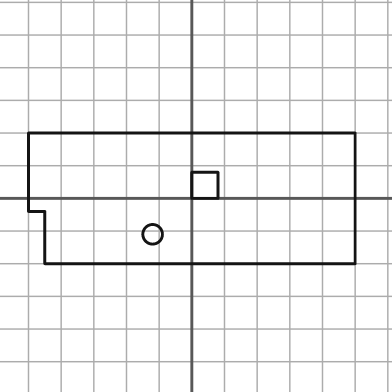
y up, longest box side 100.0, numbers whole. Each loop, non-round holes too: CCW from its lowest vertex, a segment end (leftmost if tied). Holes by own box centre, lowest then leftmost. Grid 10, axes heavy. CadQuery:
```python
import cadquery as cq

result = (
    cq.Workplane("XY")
    .moveTo(-45.0, -20.0)
    .lineTo(50.0, -20.0)
    .lineTo(50.0, 20.0)
    .lineTo(-50.0, 20.0)
    .lineTo(-50.0, -4.0)
    .lineTo(-45.0, -4.0)
    .close()
    .moveTo(-12.0, -11.0)
    .circle(3.0)
    .moveTo(0.0, 0.0)
    .lineTo(8.0, 0.0)
    .lineTo(8.0, 8.0)
    .lineTo(0.0, 8.0)
    .close()
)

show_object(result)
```